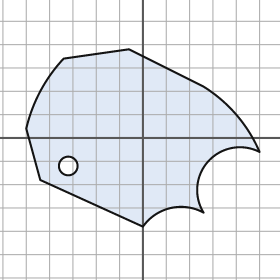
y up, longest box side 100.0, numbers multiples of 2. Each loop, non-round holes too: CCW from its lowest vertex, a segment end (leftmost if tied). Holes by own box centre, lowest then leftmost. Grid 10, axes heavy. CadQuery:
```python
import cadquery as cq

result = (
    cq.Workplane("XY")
    .moveTo(0.0, -38.0)
    .threePointArc((12.0, -30.0), (26.0, -32.0))
    .threePointArc((28.0, -10.0), (50.0, -6.0))
    .threePointArc((40.0, 10.0), (26.0, 22.0))
    .lineTo(-6.0, 38.0)
    .lineTo(-34.0, 34.0)
    .threePointArc((-44.0, 20.0), (-50.0, 4.0))
    .lineTo(-44.0, -18.0)
    .close()
    .moveTo(-32.0, -12.0)
    .circle(4.0)
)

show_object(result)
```